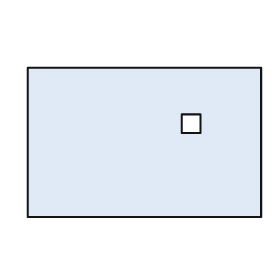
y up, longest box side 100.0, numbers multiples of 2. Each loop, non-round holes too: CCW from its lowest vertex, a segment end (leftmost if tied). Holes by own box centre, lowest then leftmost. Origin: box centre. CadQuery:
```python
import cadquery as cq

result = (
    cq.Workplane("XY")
    .moveTo(-50.0, -32.0)
    .lineTo(50.0, -32.0)
    .lineTo(50.0, 32.0)
    .lineTo(-50.0, 32.0)
    .close()
    .moveTo(16.0, 4.0)
    .lineTo(24.0, 4.0)
    .lineTo(24.0, 12.0)
    .lineTo(16.0, 12.0)
    .close()
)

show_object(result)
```